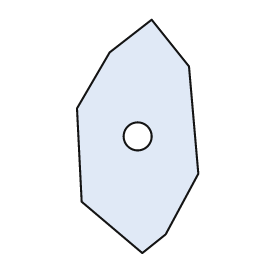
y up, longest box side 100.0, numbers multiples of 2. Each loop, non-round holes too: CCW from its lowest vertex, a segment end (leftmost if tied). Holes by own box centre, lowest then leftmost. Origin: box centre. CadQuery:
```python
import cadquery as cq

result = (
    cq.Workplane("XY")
    .moveTo(2.0, -50.0)
    .lineTo(12.0, -42.0)
    .lineTo(26.0, -16.0)
    .lineTo(22.0, 30.0)
    .lineTo(6.0, 50.0)
    .lineTo(-12.0, 36.0)
    .lineTo(-26.0, 12.0)
    .lineTo(-24.0, -28.0)
    .close()
    .moveTo(0.0, 0.0)
    .circle(6.0)
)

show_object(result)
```